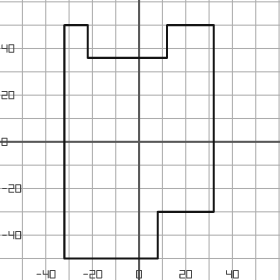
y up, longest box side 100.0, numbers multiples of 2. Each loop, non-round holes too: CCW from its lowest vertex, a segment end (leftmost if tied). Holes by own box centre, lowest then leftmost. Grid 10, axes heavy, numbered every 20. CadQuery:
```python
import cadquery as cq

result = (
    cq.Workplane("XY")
    .moveTo(-32.0, -50.0)
    .lineTo(8.0, -50.0)
    .lineTo(8.0, -30.0)
    .lineTo(32.0, -30.0)
    .lineTo(32.0, 50.0)
    .lineTo(12.0, 50.0)
    .lineTo(12.0, 36.0)
    .lineTo(-22.0, 36.0)
    .lineTo(-22.0, 50.0)
    .lineTo(-32.0, 50.0)
    .close()
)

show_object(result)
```